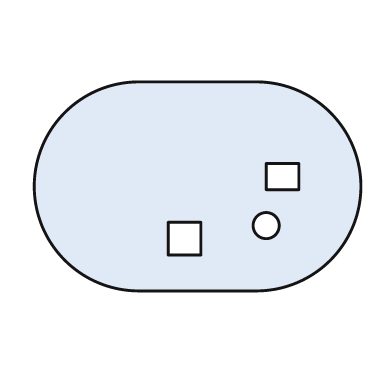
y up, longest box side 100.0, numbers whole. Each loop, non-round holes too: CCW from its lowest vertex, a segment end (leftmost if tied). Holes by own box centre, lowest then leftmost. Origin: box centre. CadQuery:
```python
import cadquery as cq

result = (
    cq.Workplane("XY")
    .moveTo(-18.0, -32.0)
    .lineTo(18.0, -32.0)
    .threePointArc((50.0, 0.0), (18.0, 32.0))
    .lineTo(-18.0, 32.0)
    .threePointArc((-50.0, 0.0), (-18.0, -32.0))
    .close()
    .moveTo(-9.0, -21.0)
    .lineTo(1.0, -21.0)
    .lineTo(1.0, -11.0)
    .lineTo(-9.0, -11.0)
    .close()
    .moveTo(21.0, -12.0)
    .circle(4.0)
    .moveTo(21.0, -1.0)
    .lineTo(31.0, -1.0)
    .lineTo(31.0, 7.0)
    .lineTo(21.0, 7.0)
    .close()
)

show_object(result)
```